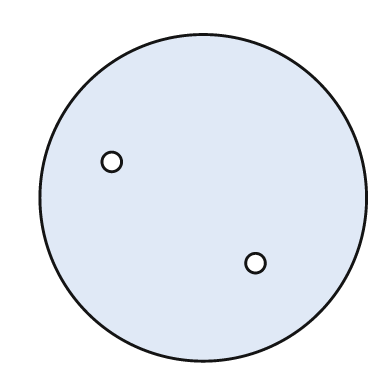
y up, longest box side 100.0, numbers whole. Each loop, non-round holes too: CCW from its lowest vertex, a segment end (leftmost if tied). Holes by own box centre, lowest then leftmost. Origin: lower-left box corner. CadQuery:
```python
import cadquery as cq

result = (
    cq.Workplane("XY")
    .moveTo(50.0, 50.0)
    .circle(50.0)
    .moveTo(66.0, 30.0)
    .circle(3.0)
    .moveTo(22.0, 61.0)
    .circle(3.0)
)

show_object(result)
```